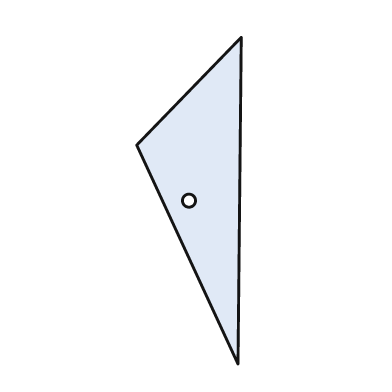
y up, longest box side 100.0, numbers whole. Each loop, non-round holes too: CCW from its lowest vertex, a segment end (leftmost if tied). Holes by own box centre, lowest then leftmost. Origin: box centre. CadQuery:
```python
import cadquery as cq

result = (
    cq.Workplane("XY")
    .moveTo(15.0, -50.0)
    .lineTo(16.0, 50.0)
    .lineTo(-16.0, 17.0)
    .close()
    .moveTo(0.0, 0.0)
    .circle(2.0)
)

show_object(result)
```